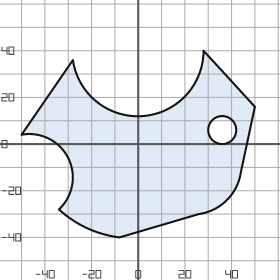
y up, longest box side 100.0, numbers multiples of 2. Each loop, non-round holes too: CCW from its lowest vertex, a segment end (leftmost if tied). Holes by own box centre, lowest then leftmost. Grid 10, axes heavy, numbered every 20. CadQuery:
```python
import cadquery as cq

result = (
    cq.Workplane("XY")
    .moveTo(-8.0, -40.0)
    .lineTo(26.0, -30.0)
    .threePointArc((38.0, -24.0), (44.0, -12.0))
    .lineTo(50.0, 16.0)
    .lineTo(28.0, 40.0)
    .threePointArc((2.0, 12.0), (-28.0, 36.0))
    .lineTo(-50.0, 4.0)
    .threePointArc((-30.0, -6.0), (-34.0, -28.0))
    .threePointArc((-22.0, -36.0), (-8.0, -40.0))
    .close()
    .moveTo(36.0, 6.0)
    .circle(6.0)
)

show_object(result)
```